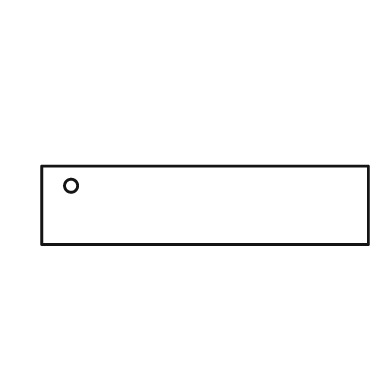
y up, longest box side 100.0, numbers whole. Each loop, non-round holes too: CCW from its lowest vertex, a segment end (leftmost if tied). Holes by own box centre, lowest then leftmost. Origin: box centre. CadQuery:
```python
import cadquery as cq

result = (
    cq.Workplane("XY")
    .moveTo(-50.0, -12.0)
    .lineTo(50.0, -12.0)
    .lineTo(50.0, 12.0)
    .lineTo(-50.0, 12.0)
    .close()
    .moveTo(-41.0, 6.0)
    .circle(2.0)
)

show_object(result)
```